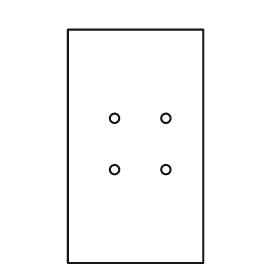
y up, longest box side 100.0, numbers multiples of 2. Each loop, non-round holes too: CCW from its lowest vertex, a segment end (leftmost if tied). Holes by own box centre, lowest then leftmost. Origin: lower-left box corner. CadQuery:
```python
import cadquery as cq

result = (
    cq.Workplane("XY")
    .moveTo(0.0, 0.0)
    .lineTo(58.0, 0.0)
    .lineTo(58.0, 100.0)
    .lineTo(0.0, 100.0)
    .close()
    .moveTo(20.0, 40.0)
    .circle(2.0)
    .moveTo(42.0, 40.0)
    .circle(2.0)
    .moveTo(20.0, 62.0)
    .circle(2.0)
    .moveTo(42.0, 62.0)
    .circle(2.0)
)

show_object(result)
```